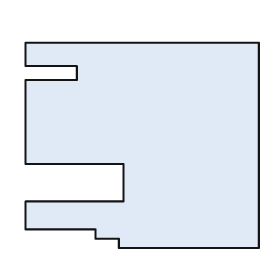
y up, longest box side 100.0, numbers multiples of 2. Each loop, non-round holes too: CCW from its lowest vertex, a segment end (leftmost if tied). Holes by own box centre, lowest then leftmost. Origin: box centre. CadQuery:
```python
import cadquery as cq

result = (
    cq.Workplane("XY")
    .moveTo(-10.0, -44.0)
    .lineTo(50.0, -44.0)
    .lineTo(50.0, 44.0)
    .lineTo(-50.0, 44.0)
    .lineTo(-50.0, 34.0)
    .lineTo(-28.0, 34.0)
    .lineTo(-28.0, 28.0)
    .lineTo(-50.0, 28.0)
    .lineTo(-50.0, -8.0)
    .lineTo(-8.0, -8.0)
    .lineTo(-8.0, -24.0)
    .lineTo(-50.0, -24.0)
    .lineTo(-50.0, -36.0)
    .lineTo(-20.0, -36.0)
    .lineTo(-20.0, -40.0)
    .lineTo(-10.0, -40.0)
    .close()
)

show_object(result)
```